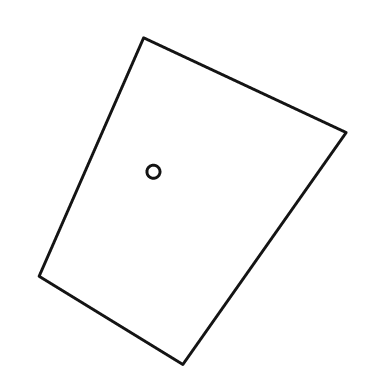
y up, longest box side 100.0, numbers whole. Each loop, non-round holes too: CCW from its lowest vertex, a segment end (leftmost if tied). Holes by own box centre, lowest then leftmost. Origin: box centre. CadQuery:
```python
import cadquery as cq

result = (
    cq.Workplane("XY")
    .moveTo(-3.0, -50.0)
    .lineTo(47.0, 21.0)
    .lineTo(-15.0, 50.0)
    .lineTo(-47.0, -23.0)
    .close()
    .moveTo(-12.0, 9.0)
    .circle(2.0)
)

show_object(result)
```